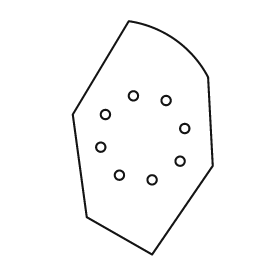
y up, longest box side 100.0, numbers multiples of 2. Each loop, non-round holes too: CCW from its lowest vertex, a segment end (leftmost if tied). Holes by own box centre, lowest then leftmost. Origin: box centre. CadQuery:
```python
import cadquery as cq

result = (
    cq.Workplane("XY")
    .moveTo(4.0, -50.0)
    .lineTo(30.0, -12.0)
    .lineTo(28.0, 26.0)
    .threePointArc((14.0, 42.0), (-6.0, 50.0))
    .lineTo(-30.0, 10.0)
    .lineTo(-24.0, -34.0)
    .close()
    .moveTo(4.0, -18.0)
    .circle(2.0)
    .moveTo(-10.0, -16.0)
    .circle(2.0)
    .moveTo(16.0, -10.0)
    .circle(2.0)
    .moveTo(-18.0, -4.0)
    .circle(2.0)
    .moveTo(18.0, 4.0)
    .circle(2.0)
    .moveTo(-16.0, 10.0)
    .circle(2.0)
    .moveTo(10.0, 16.0)
    .circle(2.0)
    .moveTo(-4.0, 18.0)
    .circle(2.0)
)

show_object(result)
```